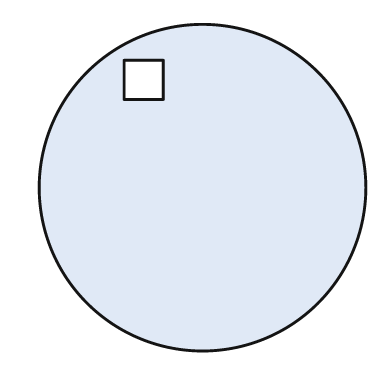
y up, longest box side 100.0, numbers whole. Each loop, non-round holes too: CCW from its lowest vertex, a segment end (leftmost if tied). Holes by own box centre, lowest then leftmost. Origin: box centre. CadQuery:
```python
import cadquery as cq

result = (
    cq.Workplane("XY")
    .moveTo(0.0, 0.0)
    .circle(50.0)
    .moveTo(-24.0, 27.0)
    .lineTo(-12.0, 27.0)
    .lineTo(-12.0, 39.0)
    .lineTo(-24.0, 39.0)
    .close()
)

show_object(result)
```